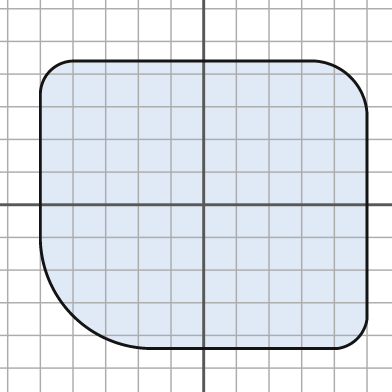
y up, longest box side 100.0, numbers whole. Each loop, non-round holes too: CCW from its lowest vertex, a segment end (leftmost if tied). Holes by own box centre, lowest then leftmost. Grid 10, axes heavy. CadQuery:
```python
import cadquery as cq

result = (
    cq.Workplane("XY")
    .moveTo(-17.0, -44.0)
    .lineTo(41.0, -44.0)
    .threePointArc((47.0, -41.0), (50.0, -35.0))
    .lineTo(50.0, 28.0)
    .threePointArc((45.0, 39.0), (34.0, 44.0))
    .lineTo(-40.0, 44.0)
    .threePointArc((-47.0, 41.0), (-50.0, 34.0))
    .lineTo(-50.0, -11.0)
    .threePointArc((-40.0, -34.0), (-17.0, -44.0))
    .close()
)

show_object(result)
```